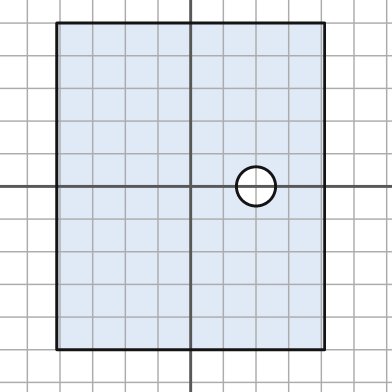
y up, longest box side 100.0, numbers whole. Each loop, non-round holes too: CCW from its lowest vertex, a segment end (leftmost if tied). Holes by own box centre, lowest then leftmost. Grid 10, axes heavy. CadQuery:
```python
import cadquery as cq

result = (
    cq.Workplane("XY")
    .moveTo(-41.0, -50.0)
    .lineTo(41.0, -50.0)
    .lineTo(41.0, 50.0)
    .lineTo(-41.0, 50.0)
    .close()
    .moveTo(20.0, 0.0)
    .circle(6.0)
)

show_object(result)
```